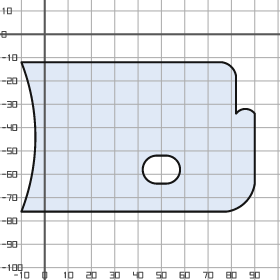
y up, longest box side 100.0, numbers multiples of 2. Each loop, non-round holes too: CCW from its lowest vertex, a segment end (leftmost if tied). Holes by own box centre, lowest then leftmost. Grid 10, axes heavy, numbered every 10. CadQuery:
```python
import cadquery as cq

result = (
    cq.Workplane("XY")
    .moveTo(-10.0, -76.0)
    .lineTo(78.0, -76.0)
    .threePointArc((86.0, -72.0), (90.0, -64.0))
    .lineTo(90.0, -34.0)
    .threePointArc((86.0, -32.0), (82.0, -34.0))
    .lineTo(82.0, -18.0)
    .threePointArc((80.0, -14.0), (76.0, -12.0))
    .lineTo(-10.0, -12.0)
    .threePointArc((-4.0, -44.0), (-10.0, -76.0))
    .close()
    .moveTo(48.0, -64.0)
    .lineTo(52.0, -64.0)
    .threePointArc((58.0, -58.0), (52.0, -52.0))
    .lineTo(48.0, -52.0)
    .threePointArc((42.0, -58.0), (48.0, -64.0))
    .close()
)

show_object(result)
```